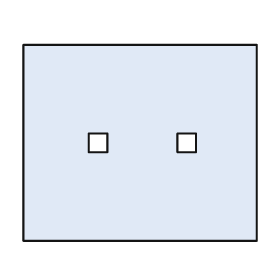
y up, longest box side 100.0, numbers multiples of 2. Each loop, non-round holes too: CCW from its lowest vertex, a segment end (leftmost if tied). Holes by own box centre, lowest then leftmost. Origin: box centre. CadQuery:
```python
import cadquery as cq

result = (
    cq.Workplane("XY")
    .moveTo(-50.0, -42.0)
    .lineTo(50.0, -42.0)
    .lineTo(50.0, 42.0)
    .lineTo(-50.0, 42.0)
    .close()
    .moveTo(-22.0, -4.0)
    .lineTo(-14.0, -4.0)
    .lineTo(-14.0, 4.0)
    .lineTo(-22.0, 4.0)
    .close()
    .moveTo(16.0, -4.0)
    .lineTo(24.0, -4.0)
    .lineTo(24.0, 4.0)
    .lineTo(16.0, 4.0)
    .close()
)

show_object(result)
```